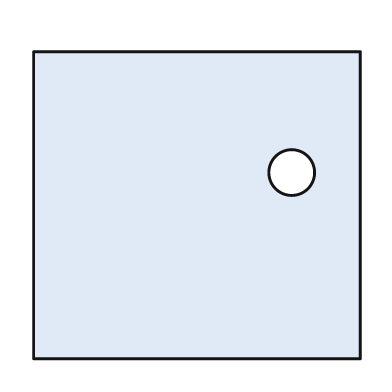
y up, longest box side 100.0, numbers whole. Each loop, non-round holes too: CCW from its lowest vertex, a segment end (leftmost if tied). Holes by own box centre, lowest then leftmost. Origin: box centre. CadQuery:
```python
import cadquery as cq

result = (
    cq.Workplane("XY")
    .moveTo(-50.0, -47.0)
    .lineTo(50.0, -47.0)
    .lineTo(50.0, 47.0)
    .lineTo(-50.0, 47.0)
    .close()
    .moveTo(29.0, 10.0)
    .circle(7.0)
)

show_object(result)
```